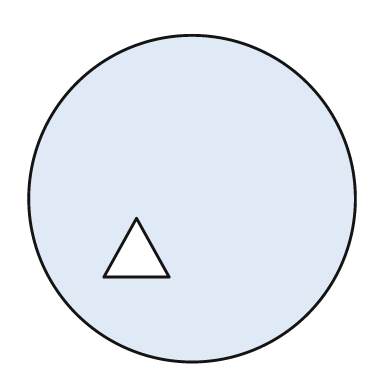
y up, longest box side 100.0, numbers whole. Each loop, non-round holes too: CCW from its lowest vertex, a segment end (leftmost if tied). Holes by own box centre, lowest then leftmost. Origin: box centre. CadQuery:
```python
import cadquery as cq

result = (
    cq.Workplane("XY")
    .moveTo(0.0, 0.0)
    .circle(50.0)
    .moveTo(-27.0, -24.0)
    .lineTo(-7.0, -24.0)
    .lineTo(-17.0, -6.0)
    .close()
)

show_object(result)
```